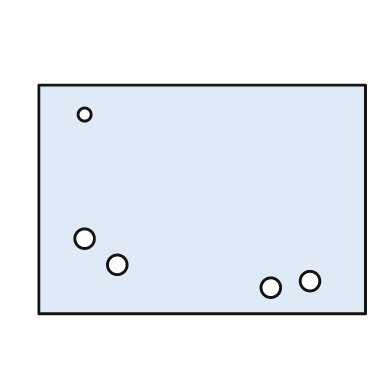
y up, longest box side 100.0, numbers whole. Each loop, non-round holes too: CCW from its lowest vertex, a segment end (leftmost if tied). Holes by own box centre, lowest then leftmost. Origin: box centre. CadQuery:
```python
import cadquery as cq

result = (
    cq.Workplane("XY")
    .moveTo(-50.0, -35.0)
    .lineTo(50.0, -35.0)
    .lineTo(50.0, 35.0)
    .lineTo(-50.0, 35.0)
    .close()
    .moveTo(21.0, -27.0)
    .circle(3.0)
    .moveTo(33.0, -25.0)
    .circle(3.0)
    .moveTo(-26.0, -20.0)
    .circle(3.0)
    .moveTo(-36.0, -12.0)
    .circle(3.0)
    .moveTo(-36.0, 26.0)
    .circle(2.0)
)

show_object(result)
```